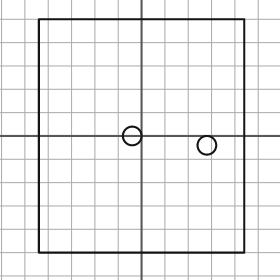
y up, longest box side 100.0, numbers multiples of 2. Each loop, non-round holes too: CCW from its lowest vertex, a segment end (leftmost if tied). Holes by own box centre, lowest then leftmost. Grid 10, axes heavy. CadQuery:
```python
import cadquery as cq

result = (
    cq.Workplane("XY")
    .moveTo(-44.0, -50.0)
    .lineTo(44.0, -50.0)
    .lineTo(44.0, 50.0)
    .lineTo(-44.0, 50.0)
    .close()
    .moveTo(28.0, -4.0)
    .circle(4.0)
    .moveTo(-4.0, 0.0)
    .circle(4.0)
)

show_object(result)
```